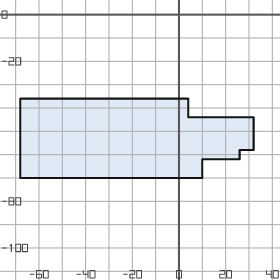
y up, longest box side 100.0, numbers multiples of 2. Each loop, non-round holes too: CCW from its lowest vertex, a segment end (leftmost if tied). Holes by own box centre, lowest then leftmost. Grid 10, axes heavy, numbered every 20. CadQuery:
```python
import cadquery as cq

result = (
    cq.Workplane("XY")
    .moveTo(-68.0, -70.0)
    .lineTo(10.0, -70.0)
    .lineTo(10.0, -62.0)
    .lineTo(26.0, -62.0)
    .lineTo(26.0, -58.0)
    .lineTo(32.0, -58.0)
    .lineTo(32.0, -44.0)
    .lineTo(4.0, -44.0)
    .lineTo(4.0, -36.0)
    .lineTo(-68.0, -36.0)
    .close()
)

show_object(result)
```